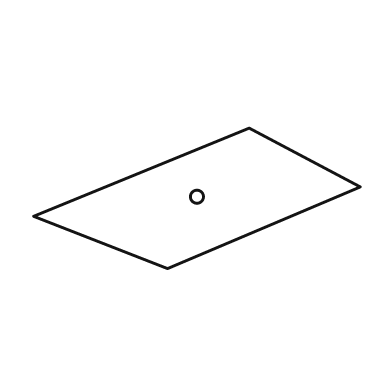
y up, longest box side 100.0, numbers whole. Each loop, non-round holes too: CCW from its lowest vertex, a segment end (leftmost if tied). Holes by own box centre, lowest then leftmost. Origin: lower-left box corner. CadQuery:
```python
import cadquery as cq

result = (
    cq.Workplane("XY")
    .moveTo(41.0, 0.0)
    .lineTo(100.0, 25.0)
    .lineTo(66.0, 43.0)
    .lineTo(0.0, 16.0)
    .close()
    .moveTo(50.0, 22.0)
    .circle(2.0)
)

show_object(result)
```